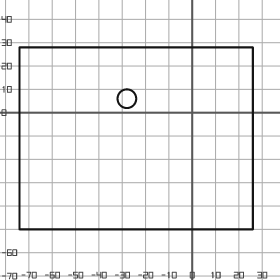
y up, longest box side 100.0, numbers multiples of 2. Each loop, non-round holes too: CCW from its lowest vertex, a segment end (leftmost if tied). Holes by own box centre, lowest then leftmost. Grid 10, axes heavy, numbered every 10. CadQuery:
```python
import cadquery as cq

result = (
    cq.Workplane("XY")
    .moveTo(-74.0, -50.0)
    .lineTo(26.0, -50.0)
    .lineTo(26.0, 28.0)
    .lineTo(-74.0, 28.0)
    .close()
    .moveTo(-28.0, 6.0)
    .circle(4.0)
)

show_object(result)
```